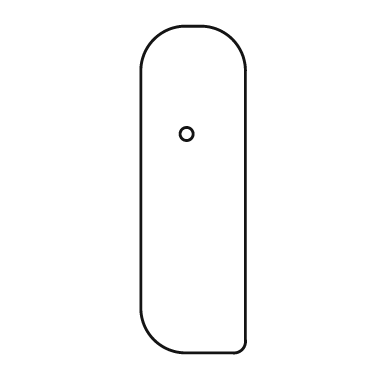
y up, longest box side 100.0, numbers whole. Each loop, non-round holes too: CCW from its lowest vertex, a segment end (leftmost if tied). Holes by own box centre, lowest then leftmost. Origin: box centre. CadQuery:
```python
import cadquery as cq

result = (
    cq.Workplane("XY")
    .moveTo(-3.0, -50.0)
    .lineTo(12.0, -50.0)
    .threePointArc((15.0, -49.0), (16.0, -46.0))
    .lineTo(16.0, 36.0)
    .threePointArc((12.0, 46.0), (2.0, 50.0))
    .lineTo(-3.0, 50.0)
    .threePointArc((-12.0, 46.0), (-16.0, 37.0))
    .lineTo(-16.0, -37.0)
    .threePointArc((-12.0, -46.0), (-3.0, -50.0))
    .close()
    .moveTo(-2.0, 17.0)
    .circle(2.0)
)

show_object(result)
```